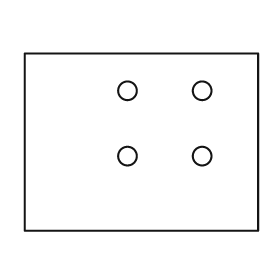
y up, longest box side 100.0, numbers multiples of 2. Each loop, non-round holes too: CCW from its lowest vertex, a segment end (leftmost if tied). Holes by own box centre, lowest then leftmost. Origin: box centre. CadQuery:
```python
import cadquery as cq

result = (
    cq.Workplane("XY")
    .moveTo(-50.0, -38.0)
    .lineTo(50.0, -38.0)
    .lineTo(50.0, 38.0)
    .lineTo(-50.0, 38.0)
    .close()
    .moveTo(-6.0, -6.0)
    .circle(4.0)
    .moveTo(26.0, -6.0)
    .circle(4.0)
    .moveTo(-6.0, 22.0)
    .circle(4.0)
    .moveTo(26.0, 22.0)
    .circle(4.0)
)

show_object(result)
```